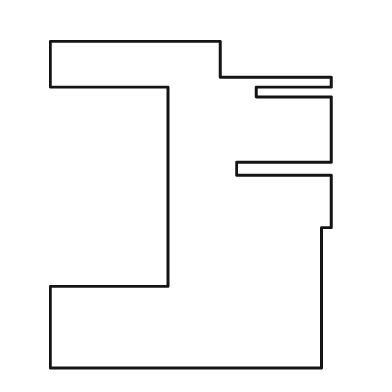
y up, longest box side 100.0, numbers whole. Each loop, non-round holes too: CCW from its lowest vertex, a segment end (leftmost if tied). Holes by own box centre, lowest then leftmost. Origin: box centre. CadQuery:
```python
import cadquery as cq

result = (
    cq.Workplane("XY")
    .moveTo(-43.0, -50.0)
    .lineTo(40.0, -50.0)
    .lineTo(40.0, -7.0)
    .lineTo(43.0, -7.0)
    .lineTo(43.0, 9.0)
    .lineTo(14.0, 9.0)
    .lineTo(14.0, 13.0)
    .lineTo(43.0, 13.0)
    .lineTo(43.0, 33.0)
    .lineTo(20.0, 33.0)
    .lineTo(20.0, 36.0)
    .lineTo(43.0, 36.0)
    .lineTo(43.0, 39.0)
    .lineTo(9.0, 39.0)
    .lineTo(9.0, 50.0)
    .lineTo(-43.0, 50.0)
    .lineTo(-43.0, 36.0)
    .lineTo(-7.0, 36.0)
    .lineTo(-7.0, -25.0)
    .lineTo(-43.0, -25.0)
    .close()
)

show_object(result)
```